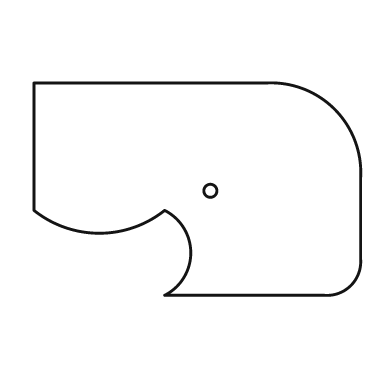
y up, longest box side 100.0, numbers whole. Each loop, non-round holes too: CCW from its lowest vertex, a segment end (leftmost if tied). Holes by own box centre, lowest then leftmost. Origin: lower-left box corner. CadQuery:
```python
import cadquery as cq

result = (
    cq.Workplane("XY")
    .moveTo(40.0, 0.0)
    .lineTo(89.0, 0.0)
    .threePointArc((97.0, 3.0), (100.0, 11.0))
    .lineTo(100.0, 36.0)
    .threePointArc((92.0, 57.0), (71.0, 65.0))
    .lineTo(0.0, 65.0)
    .lineTo(0.0, 26.0)
    .threePointArc((20.0, 19.0), (40.0, 26.0))
    .threePointArc((48.0, 13.0), (40.0, 0.0))
    .close()
    .moveTo(54.0, 32.0)
    .circle(2.0)
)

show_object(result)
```